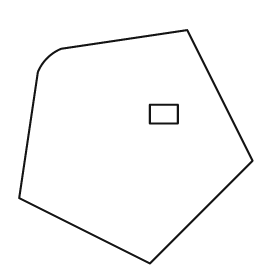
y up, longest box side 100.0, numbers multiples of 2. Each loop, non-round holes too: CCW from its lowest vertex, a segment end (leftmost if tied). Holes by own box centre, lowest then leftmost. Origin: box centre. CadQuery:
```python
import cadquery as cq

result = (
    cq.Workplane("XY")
    .moveTo(6.0, -50.0)
    .lineTo(50.0, -6.0)
    .lineTo(22.0, 50.0)
    .lineTo(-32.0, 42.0)
    .threePointArc((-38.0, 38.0), (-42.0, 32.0))
    .lineTo(-50.0, -22.0)
    .close()
    .moveTo(6.0, 10.0)
    .lineTo(18.0, 10.0)
    .lineTo(18.0, 18.0)
    .lineTo(6.0, 18.0)
    .close()
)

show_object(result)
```